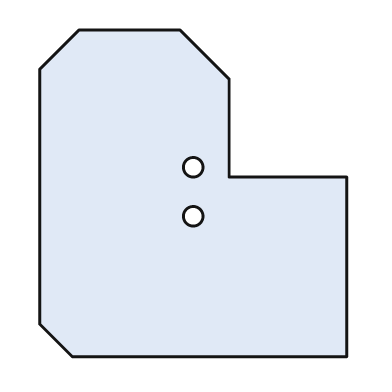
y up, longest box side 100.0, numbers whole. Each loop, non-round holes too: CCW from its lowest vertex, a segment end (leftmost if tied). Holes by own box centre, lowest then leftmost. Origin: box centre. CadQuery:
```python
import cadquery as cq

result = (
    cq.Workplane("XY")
    .moveTo(-37.0, -50.0)
    .lineTo(47.0, -50.0)
    .lineTo(47.0, 5.0)
    .lineTo(11.0, 5.0)
    .lineTo(11.0, 35.0)
    .lineTo(-4.0, 50.0)
    .lineTo(-35.0, 50.0)
    .lineTo(-47.0, 38.0)
    .lineTo(-47.0, -40.0)
    .close()
    .moveTo(0.0, -7.0)
    .circle(3.0)
    .moveTo(0.0, 8.0)
    .circle(3.0)
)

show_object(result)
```